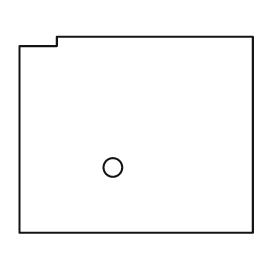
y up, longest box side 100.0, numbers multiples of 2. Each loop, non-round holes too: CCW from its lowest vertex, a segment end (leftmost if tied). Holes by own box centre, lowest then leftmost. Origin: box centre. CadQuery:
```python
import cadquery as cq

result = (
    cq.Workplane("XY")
    .moveTo(-50.0, -42.0)
    .lineTo(50.0, -42.0)
    .lineTo(50.0, 42.0)
    .lineTo(-34.0, 42.0)
    .lineTo(-34.0, 38.0)
    .lineTo(-50.0, 38.0)
    .close()
    .moveTo(-10.0, -14.0)
    .circle(4.0)
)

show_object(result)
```